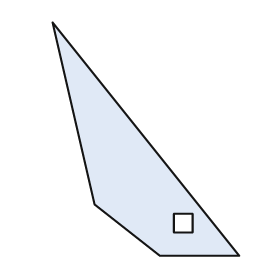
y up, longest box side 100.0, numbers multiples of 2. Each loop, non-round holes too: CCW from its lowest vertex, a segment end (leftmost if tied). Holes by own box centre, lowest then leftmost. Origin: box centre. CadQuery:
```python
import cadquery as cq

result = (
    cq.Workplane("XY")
    .moveTo(6.0, -50.0)
    .lineTo(40.0, -50.0)
    .lineTo(-40.0, 50.0)
    .lineTo(-22.0, -28.0)
    .close()
    .moveTo(12.0, -40.0)
    .lineTo(20.0, -40.0)
    .lineTo(20.0, -32.0)
    .lineTo(12.0, -32.0)
    .close()
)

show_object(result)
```